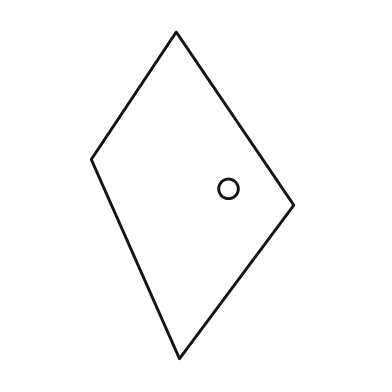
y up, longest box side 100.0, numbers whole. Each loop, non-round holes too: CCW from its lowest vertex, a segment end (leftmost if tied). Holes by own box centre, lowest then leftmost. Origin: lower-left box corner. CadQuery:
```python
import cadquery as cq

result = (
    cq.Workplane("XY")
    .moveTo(27.0, 0.0)
    .lineTo(62.0, 47.0)
    .lineTo(26.0, 100.0)
    .lineTo(0.0, 61.0)
    .close()
    .moveTo(42.0, 52.0)
    .circle(3.0)
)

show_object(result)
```